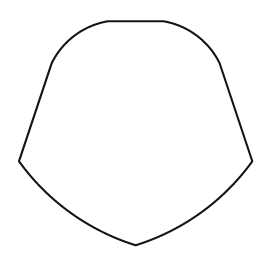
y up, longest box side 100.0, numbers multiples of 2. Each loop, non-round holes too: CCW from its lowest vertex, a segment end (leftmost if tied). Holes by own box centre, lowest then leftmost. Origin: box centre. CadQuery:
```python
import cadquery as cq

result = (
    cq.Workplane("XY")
    .moveTo(0.0, -48.0)
    .threePointArc((28.0, -34.0), (50.0, -12.0))
    .lineTo(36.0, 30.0)
    .threePointArc((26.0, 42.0), (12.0, 48.0))
    .lineTo(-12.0, 48.0)
    .threePointArc((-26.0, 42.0), (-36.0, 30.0))
    .lineTo(-50.0, -12.0)
    .threePointArc((-28.0, -34.0), (0.0, -48.0))
    .close()
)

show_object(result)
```